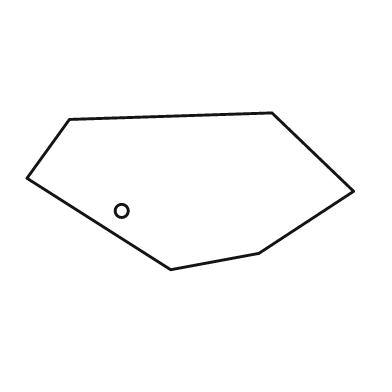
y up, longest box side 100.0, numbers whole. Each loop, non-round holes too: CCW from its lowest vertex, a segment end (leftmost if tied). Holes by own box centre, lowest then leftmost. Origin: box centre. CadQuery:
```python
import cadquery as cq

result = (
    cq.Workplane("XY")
    .moveTo(-6.0, -24.0)
    .lineTo(21.0, -19.0)
    .lineTo(50.0, 0.0)
    .lineTo(25.0, 24.0)
    .lineTo(-37.0, 22.0)
    .lineTo(-50.0, 4.0)
    .close()
    .moveTo(-21.0, -6.0)
    .circle(2.0)
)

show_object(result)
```